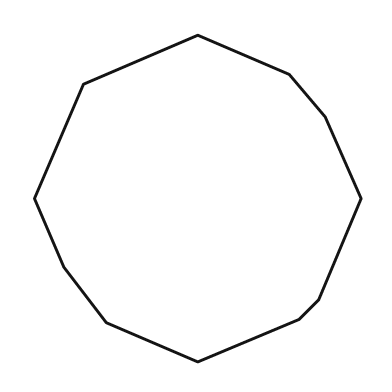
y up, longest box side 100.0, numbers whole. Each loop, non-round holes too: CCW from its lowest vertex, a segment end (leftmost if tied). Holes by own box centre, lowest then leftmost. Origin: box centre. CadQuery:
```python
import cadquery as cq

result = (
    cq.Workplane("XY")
    .moveTo(0.0, -50.0)
    .lineTo(31.0, -37.0)
    .lineTo(37.0, -31.0)
    .lineTo(50.0, 0.0)
    .lineTo(39.0, 25.0)
    .lineTo(28.0, 38.0)
    .lineTo(0.0, 50.0)
    .lineTo(-35.0, 35.0)
    .lineTo(-50.0, 0.0)
    .lineTo(-41.0, -21.0)
    .lineTo(-28.0, -38.0)
    .close()
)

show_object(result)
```